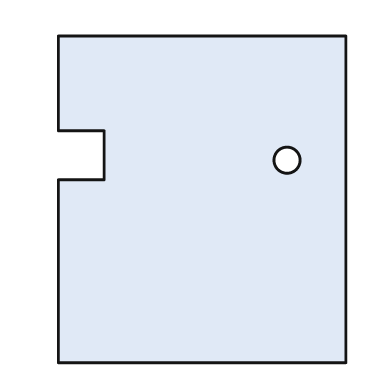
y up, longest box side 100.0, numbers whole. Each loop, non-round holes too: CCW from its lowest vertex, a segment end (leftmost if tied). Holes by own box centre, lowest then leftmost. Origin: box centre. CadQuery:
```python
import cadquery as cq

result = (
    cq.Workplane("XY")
    .moveTo(-44.0, -50.0)
    .lineTo(44.0, -50.0)
    .lineTo(44.0, 50.0)
    .lineTo(-44.0, 50.0)
    .lineTo(-44.0, 21.0)
    .lineTo(-30.0, 21.0)
    .lineTo(-30.0, 6.0)
    .lineTo(-44.0, 6.0)
    .close()
    .moveTo(26.0, 12.0)
    .circle(4.0)
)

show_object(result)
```